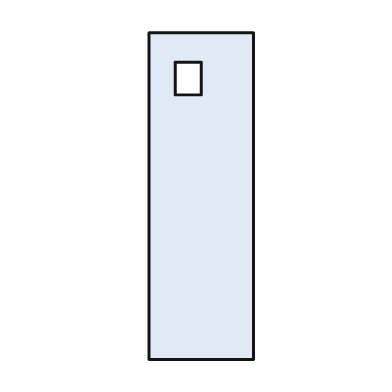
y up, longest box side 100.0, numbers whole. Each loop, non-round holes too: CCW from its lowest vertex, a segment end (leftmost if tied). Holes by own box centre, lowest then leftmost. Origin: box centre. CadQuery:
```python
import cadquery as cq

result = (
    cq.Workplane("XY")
    .moveTo(-16.0, -50.0)
    .lineTo(16.0, -50.0)
    .lineTo(16.0, 50.0)
    .lineTo(-16.0, 50.0)
    .close()
    .moveTo(-8.0, 31.0)
    .lineTo(0.0, 31.0)
    .lineTo(0.0, 41.0)
    .lineTo(-8.0, 41.0)
    .close()
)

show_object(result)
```